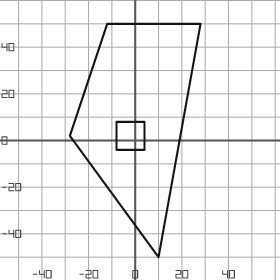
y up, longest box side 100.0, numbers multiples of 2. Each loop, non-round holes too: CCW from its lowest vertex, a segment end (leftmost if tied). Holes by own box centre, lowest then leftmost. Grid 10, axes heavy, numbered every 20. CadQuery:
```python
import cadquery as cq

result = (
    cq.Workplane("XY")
    .moveTo(10.0, -50.0)
    .lineTo(28.0, 50.0)
    .lineTo(-12.0, 50.0)
    .lineTo(-28.0, 2.0)
    .close()
    .moveTo(-8.0, -4.0)
    .lineTo(4.0, -4.0)
    .lineTo(4.0, 8.0)
    .lineTo(-8.0, 8.0)
    .close()
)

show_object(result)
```